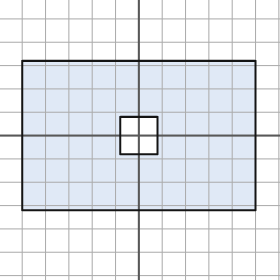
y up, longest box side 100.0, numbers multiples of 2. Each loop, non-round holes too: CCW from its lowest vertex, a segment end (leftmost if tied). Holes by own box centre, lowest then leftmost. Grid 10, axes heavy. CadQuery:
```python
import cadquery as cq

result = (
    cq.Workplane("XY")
    .moveTo(-50.0, -32.0)
    .lineTo(50.0, -32.0)
    .lineTo(50.0, 32.0)
    .lineTo(-50.0, 32.0)
    .close()
    .moveTo(-8.0, -8.0)
    .lineTo(8.0, -8.0)
    .lineTo(8.0, 8.0)
    .lineTo(-8.0, 8.0)
    .close()
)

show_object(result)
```